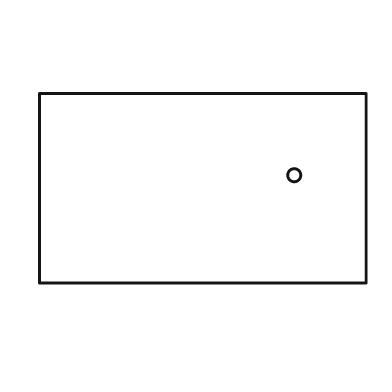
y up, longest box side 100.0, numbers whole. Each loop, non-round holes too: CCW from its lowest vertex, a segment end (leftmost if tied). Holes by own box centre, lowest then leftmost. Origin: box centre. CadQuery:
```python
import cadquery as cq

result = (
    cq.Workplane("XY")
    .moveTo(-50.0, -29.0)
    .lineTo(50.0, -29.0)
    .lineTo(50.0, 29.0)
    .lineTo(-50.0, 29.0)
    .close()
    .moveTo(28.0, 4.0)
    .circle(2.0)
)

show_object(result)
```